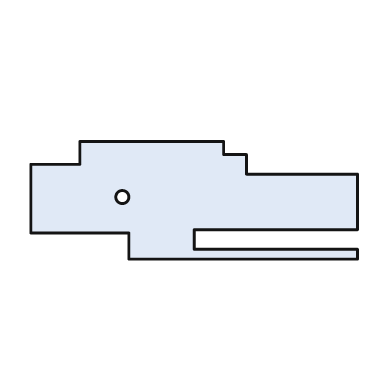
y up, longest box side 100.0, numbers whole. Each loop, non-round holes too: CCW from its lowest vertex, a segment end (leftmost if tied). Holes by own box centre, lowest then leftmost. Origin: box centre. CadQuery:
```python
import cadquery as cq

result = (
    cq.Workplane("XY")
    .moveTo(-20.0, -18.0)
    .lineTo(50.0, -18.0)
    .lineTo(50.0, -15.0)
    .lineTo(0.0, -15.0)
    .lineTo(0.0, -9.0)
    .lineTo(50.0, -9.0)
    .lineTo(50.0, 8.0)
    .lineTo(16.0, 8.0)
    .lineTo(16.0, 14.0)
    .lineTo(9.0, 14.0)
    .lineTo(9.0, 18.0)
    .lineTo(-35.0, 18.0)
    .lineTo(-35.0, 11.0)
    .lineTo(-50.0, 11.0)
    .lineTo(-50.0, -10.0)
    .lineTo(-20.0, -10.0)
    .close()
    .moveTo(-22.0, 1.0)
    .circle(2.0)
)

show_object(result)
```